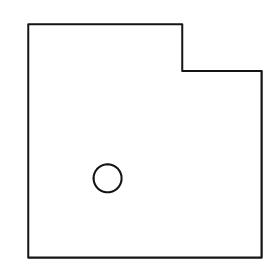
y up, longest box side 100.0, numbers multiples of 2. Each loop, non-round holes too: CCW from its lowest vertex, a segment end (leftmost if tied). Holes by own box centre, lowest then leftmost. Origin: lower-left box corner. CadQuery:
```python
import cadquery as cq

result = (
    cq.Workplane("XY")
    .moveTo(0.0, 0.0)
    .lineTo(100.0, 0.0)
    .lineTo(100.0, 80.0)
    .lineTo(66.0, 80.0)
    .lineTo(66.0, 100.0)
    .lineTo(0.0, 100.0)
    .close()
    .moveTo(34.0, 34.0)
    .circle(6.0)
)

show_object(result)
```